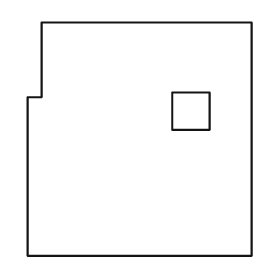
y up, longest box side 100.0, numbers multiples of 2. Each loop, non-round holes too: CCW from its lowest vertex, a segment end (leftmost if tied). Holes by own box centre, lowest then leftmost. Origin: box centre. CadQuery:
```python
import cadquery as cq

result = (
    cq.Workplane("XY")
    .moveTo(-48.0, -50.0)
    .lineTo(48.0, -50.0)
    .lineTo(48.0, 50.0)
    .lineTo(-42.0, 50.0)
    .lineTo(-42.0, 18.0)
    .lineTo(-48.0, 18.0)
    .close()
    .moveTo(14.0, 4.0)
    .lineTo(30.0, 4.0)
    .lineTo(30.0, 20.0)
    .lineTo(14.0, 20.0)
    .close()
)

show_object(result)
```